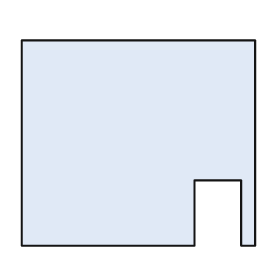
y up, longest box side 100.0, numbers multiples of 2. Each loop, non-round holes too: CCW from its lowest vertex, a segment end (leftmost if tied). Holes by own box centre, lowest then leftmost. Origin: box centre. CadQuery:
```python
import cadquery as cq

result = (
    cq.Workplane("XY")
    .moveTo(-50.0, -44.0)
    .lineTo(24.0, -44.0)
    .lineTo(24.0, -16.0)
    .lineTo(44.0, -16.0)
    .lineTo(44.0, -44.0)
    .lineTo(50.0, -44.0)
    .lineTo(50.0, 44.0)
    .lineTo(-50.0, 44.0)
    .close()
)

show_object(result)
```